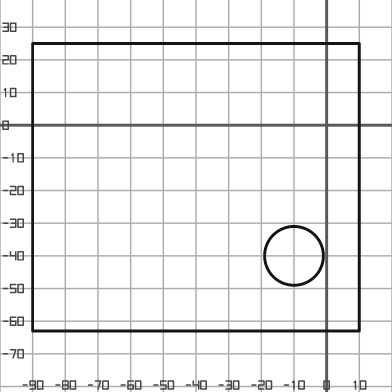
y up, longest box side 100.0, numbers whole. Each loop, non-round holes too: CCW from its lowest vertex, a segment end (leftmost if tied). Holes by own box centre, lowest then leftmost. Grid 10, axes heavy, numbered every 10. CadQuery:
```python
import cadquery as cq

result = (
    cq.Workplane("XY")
    .moveTo(-90.0, -63.0)
    .lineTo(10.0, -63.0)
    .lineTo(10.0, 25.0)
    .lineTo(-90.0, 25.0)
    .close()
    .moveTo(-10.0, -40.0)
    .circle(9.0)
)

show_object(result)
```